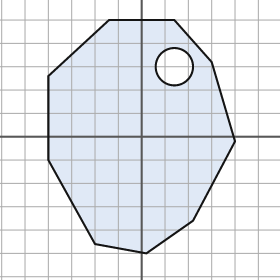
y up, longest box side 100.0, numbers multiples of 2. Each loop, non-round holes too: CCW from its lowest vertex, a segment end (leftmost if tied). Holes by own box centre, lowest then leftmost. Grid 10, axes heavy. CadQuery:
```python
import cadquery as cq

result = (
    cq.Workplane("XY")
    .moveTo(2.0, -50.0)
    .lineTo(22.0, -36.0)
    .lineTo(40.0, -2.0)
    .lineTo(30.0, 32.0)
    .lineTo(14.0, 50.0)
    .lineTo(-14.0, 50.0)
    .lineTo(-40.0, 26.0)
    .lineTo(-40.0, -10.0)
    .lineTo(-20.0, -46.0)
    .close()
    .moveTo(14.0, 30.0)
    .circle(8.0)
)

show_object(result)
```